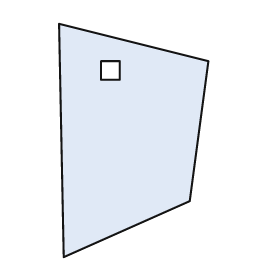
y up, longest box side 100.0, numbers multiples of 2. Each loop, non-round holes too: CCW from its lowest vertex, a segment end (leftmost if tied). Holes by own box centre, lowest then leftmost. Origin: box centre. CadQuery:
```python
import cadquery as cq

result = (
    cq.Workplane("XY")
    .moveTo(-30.0, -50.0)
    .lineTo(24.0, -26.0)
    .lineTo(32.0, 34.0)
    .lineTo(-32.0, 50.0)
    .close()
    .moveTo(-14.0, 26.0)
    .lineTo(-6.0, 26.0)
    .lineTo(-6.0, 34.0)
    .lineTo(-14.0, 34.0)
    .close()
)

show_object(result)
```